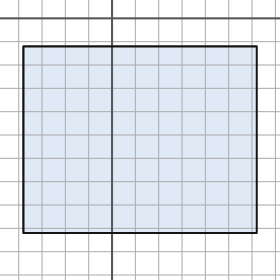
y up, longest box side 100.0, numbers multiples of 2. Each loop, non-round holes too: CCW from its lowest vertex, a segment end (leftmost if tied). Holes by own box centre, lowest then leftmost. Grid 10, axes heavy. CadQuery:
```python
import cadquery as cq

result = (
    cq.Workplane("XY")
    .moveTo(-38.0, -92.0)
    .lineTo(62.0, -92.0)
    .lineTo(62.0, -12.0)
    .lineTo(-38.0, -12.0)
    .close()
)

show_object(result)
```